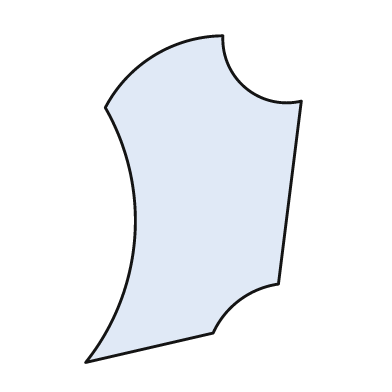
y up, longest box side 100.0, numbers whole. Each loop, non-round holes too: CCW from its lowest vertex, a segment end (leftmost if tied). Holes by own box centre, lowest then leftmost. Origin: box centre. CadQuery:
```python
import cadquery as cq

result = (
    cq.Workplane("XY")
    .moveTo(-33.0, -50.0)
    .lineTo(6.0, -41.0)
    .threePointArc((14.0, -31.0), (26.0, -26.0))
    .lineTo(33.0, 30.0)
    .threePointArc((16.0, 34.0), (9.0, 50.0))
    .threePointArc((-12.0, 44.0), (-27.0, 28.0))
    .threePointArc((-18.0, -12.0), (-33.0, -50.0))
    .close()
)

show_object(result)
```